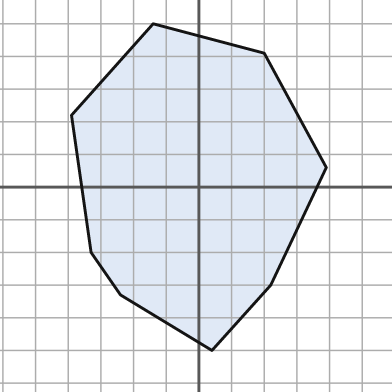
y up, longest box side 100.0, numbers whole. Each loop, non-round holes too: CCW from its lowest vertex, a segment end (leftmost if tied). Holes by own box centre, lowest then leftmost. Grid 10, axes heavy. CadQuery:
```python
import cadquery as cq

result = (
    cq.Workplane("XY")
    .moveTo(4.0, -50.0)
    .lineTo(22.0, -30.0)
    .lineTo(39.0, 6.0)
    .lineTo(20.0, 41.0)
    .lineTo(-14.0, 50.0)
    .lineTo(-39.0, 22.0)
    .lineTo(-33.0, -20.0)
    .lineTo(-24.0, -33.0)
    .close()
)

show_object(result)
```